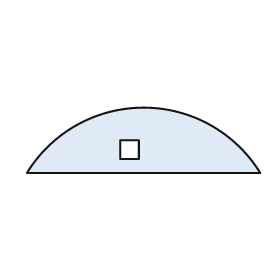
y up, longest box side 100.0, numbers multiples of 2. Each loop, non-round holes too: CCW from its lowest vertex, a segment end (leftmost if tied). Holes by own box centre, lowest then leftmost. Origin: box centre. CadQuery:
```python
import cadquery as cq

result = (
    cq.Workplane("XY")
    .moveTo(-50.0, -14.0)
    .lineTo(50.0, -14.0)
    .threePointArc((0.0, 14.0), (-50.0, -14.0))
    .close()
    .moveTo(-10.0, -8.0)
    .lineTo(-2.0, -8.0)
    .lineTo(-2.0, 0.0)
    .lineTo(-10.0, 0.0)
    .close()
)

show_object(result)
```